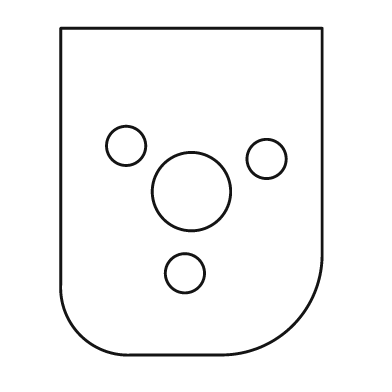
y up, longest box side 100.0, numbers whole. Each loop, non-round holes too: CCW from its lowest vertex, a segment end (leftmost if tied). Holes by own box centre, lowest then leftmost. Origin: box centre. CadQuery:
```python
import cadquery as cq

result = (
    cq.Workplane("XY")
    .moveTo(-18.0, -50.0)
    .lineTo(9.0, -50.0)
    .threePointArc((31.0, -41.0), (40.0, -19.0))
    .lineTo(40.0, 50.0)
    .lineTo(-40.0, 50.0)
    .lineTo(-40.0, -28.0)
    .threePointArc((-34.0, -44.0), (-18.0, -50.0))
    .close()
    .moveTo(-2.0, -25.0)
    .circle(6.0)
    .moveTo(0.0, 0.0)
    .circle(12.0)
    .moveTo(23.0, 10.0)
    .circle(6.0)
    .moveTo(-20.0, 14.0)
    .circle(6.0)
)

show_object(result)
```